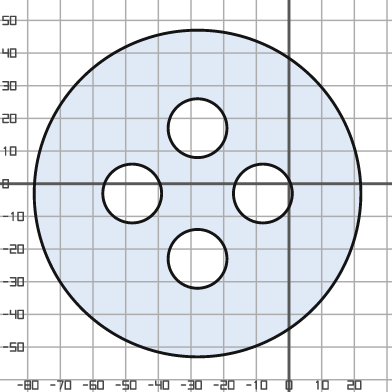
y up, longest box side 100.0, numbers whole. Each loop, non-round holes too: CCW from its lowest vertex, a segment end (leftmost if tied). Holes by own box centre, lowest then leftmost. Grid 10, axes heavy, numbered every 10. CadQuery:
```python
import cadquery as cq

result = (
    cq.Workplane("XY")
    .moveTo(-28.0, -3.0)
    .circle(50.0)
    .moveTo(-28.0, -23.0)
    .circle(9.0)
    .moveTo(-48.0, -3.0)
    .circle(9.0)
    .moveTo(-8.0, -3.0)
    .circle(9.0)
    .moveTo(-28.0, 17.0)
    .circle(9.0)
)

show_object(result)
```